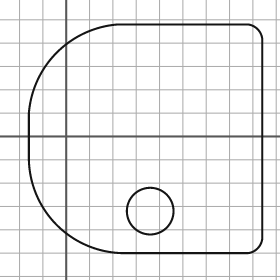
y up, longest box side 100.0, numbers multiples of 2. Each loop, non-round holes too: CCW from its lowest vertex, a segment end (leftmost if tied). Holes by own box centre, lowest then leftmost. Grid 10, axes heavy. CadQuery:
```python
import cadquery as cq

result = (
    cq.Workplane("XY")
    .moveTo(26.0, -50.0)
    .lineTo(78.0, -50.0)
    .threePointArc((82.0, -48.0), (84.0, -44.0))
    .lineTo(84.0, 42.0)
    .threePointArc((82.0, 46.0), (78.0, 48.0))
    .lineTo(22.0, 48.0)
    .threePointArc((-4.0, 36.0), (-16.0, 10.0))
    .lineTo(-16.0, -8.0)
    .threePointArc((-4.0, -38.0), (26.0, -50.0))
    .close()
    .moveTo(36.0, -32.0)
    .circle(10.0)
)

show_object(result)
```